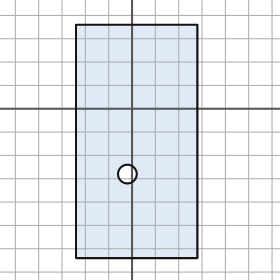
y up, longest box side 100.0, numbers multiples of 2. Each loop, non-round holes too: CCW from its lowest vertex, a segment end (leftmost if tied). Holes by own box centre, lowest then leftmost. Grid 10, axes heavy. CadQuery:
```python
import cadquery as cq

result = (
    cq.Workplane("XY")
    .moveTo(-24.0, -64.0)
    .lineTo(28.0, -64.0)
    .lineTo(28.0, 36.0)
    .lineTo(-24.0, 36.0)
    .close()
    .moveTo(-2.0, -28.0)
    .circle(4.0)
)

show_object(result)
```